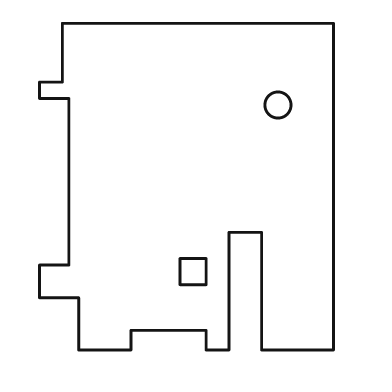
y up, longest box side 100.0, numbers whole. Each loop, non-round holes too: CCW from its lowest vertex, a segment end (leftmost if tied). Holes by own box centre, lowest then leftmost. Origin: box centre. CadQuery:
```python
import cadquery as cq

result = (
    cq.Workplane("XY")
    .moveTo(-33.0, -50.0)
    .lineTo(-17.0, -50.0)
    .lineTo(-17.0, -44.0)
    .lineTo(6.0, -44.0)
    .lineTo(6.0, -50.0)
    .lineTo(13.0, -50.0)
    .lineTo(13.0, -14.0)
    .lineTo(23.0, -14.0)
    .lineTo(23.0, -50.0)
    .lineTo(45.0, -50.0)
    .lineTo(45.0, 50.0)
    .lineTo(-38.0, 50.0)
    .lineTo(-38.0, 32.0)
    .lineTo(-45.0, 32.0)
    .lineTo(-45.0, 27.0)
    .lineTo(-36.0, 27.0)
    .lineTo(-36.0, -24.0)
    .lineTo(-45.0, -24.0)
    .lineTo(-45.0, -34.0)
    .lineTo(-33.0, -34.0)
    .close()
    .moveTo(-2.0, -30.0)
    .lineTo(6.0, -30.0)
    .lineTo(6.0, -22.0)
    .lineTo(-2.0, -22.0)
    .close()
    .moveTo(28.0, 25.0)
    .circle(4.0)
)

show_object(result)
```